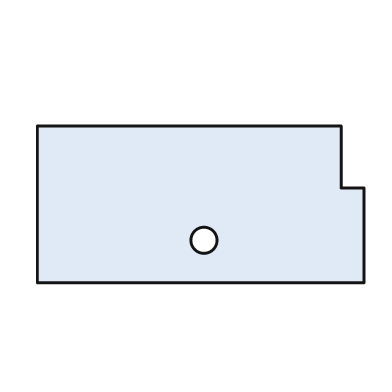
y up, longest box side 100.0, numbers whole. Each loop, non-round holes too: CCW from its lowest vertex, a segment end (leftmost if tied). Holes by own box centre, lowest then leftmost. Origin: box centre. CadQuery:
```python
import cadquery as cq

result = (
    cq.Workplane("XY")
    .moveTo(-50.0, -24.0)
    .lineTo(50.0, -24.0)
    .lineTo(50.0, 5.0)
    .lineTo(43.0, 5.0)
    .lineTo(43.0, 24.0)
    .lineTo(-50.0, 24.0)
    .close()
    .moveTo(1.0, -11.0)
    .circle(4.0)
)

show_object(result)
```